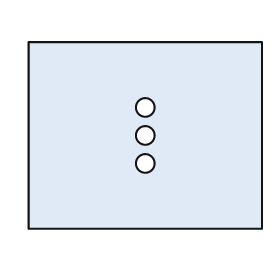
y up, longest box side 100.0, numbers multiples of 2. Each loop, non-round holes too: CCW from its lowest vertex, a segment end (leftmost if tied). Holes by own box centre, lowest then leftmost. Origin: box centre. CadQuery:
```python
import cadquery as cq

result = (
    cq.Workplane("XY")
    .moveTo(-50.0, -40.0)
    .lineTo(50.0, -40.0)
    .lineTo(50.0, 40.0)
    .lineTo(-50.0, 40.0)
    .close()
    .moveTo(0.0, -12.0)
    .circle(4.0)
    .moveTo(0.0, 0.0)
    .circle(4.0)
    .moveTo(0.0, 12.0)
    .circle(4.0)
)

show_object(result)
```